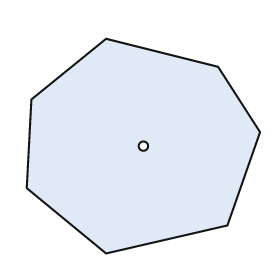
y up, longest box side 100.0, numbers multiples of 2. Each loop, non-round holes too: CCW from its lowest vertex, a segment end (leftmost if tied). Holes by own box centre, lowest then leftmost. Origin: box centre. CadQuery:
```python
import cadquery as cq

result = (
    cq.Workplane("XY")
    .moveTo(-16.0, -46.0)
    .lineTo(36.0, -34.0)
    .lineTo(50.0, 6.0)
    .lineTo(32.0, 34.0)
    .lineTo(-16.0, 46.0)
    .lineTo(-48.0, 20.0)
    .lineTo(-50.0, -18.0)
    .close()
    .moveTo(0.0, 0.0)
    .circle(2.0)
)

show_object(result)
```